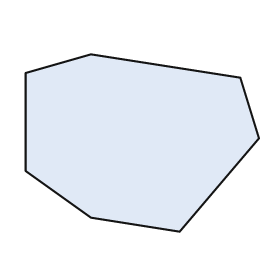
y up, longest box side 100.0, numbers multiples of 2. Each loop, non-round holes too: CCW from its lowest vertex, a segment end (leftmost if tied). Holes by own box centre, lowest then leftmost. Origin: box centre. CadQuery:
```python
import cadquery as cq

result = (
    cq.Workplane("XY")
    .moveTo(16.0, -38.0)
    .lineTo(50.0, 2.0)
    .lineTo(42.0, 28.0)
    .lineTo(-22.0, 38.0)
    .lineTo(-50.0, 30.0)
    .lineTo(-50.0, -12.0)
    .lineTo(-22.0, -32.0)
    .close()
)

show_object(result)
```